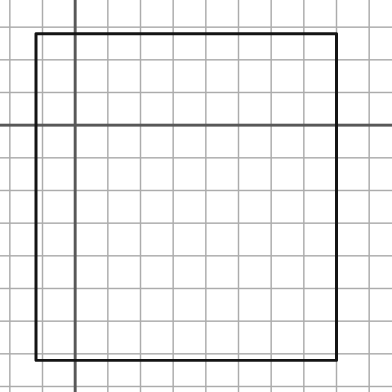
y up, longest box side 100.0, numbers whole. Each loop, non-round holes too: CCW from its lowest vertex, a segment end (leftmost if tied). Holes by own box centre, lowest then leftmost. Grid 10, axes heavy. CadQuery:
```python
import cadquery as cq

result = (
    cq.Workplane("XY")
    .moveTo(-12.0, -72.0)
    .lineTo(80.0, -72.0)
    .lineTo(80.0, 28.0)
    .lineTo(-12.0, 28.0)
    .close()
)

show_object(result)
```